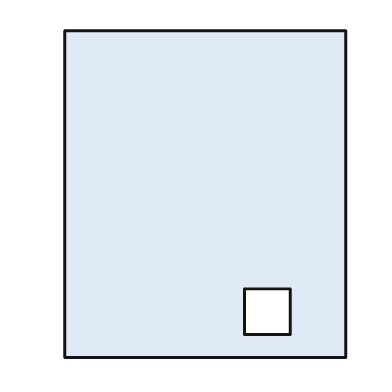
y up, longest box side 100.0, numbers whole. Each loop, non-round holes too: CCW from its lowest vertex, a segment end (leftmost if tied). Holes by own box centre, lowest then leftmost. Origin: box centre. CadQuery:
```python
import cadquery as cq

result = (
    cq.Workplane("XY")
    .moveTo(-43.0, -50.0)
    .lineTo(43.0, -50.0)
    .lineTo(43.0, 50.0)
    .lineTo(-43.0, 50.0)
    .close()
    .moveTo(12.0, -43.0)
    .lineTo(26.0, -43.0)
    .lineTo(26.0, -29.0)
    .lineTo(12.0, -29.0)
    .close()
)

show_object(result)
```